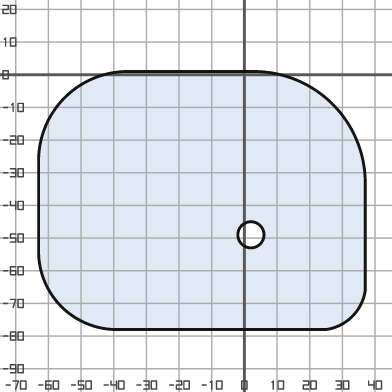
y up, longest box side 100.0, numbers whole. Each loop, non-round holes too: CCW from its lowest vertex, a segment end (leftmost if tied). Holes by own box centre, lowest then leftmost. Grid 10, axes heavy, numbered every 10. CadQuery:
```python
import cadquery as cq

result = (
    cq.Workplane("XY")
    .moveTo(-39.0, -78.0)
    .lineTo(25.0, -78.0)
    .threePointArc((33.0, -74.0), (37.0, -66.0))
    .lineTo(37.0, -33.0)
    .threePointArc((27.0, -9.0), (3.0, 1.0))
    .lineTo(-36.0, 1.0)
    .threePointArc((-55.0, -7.0), (-63.0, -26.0))
    .lineTo(-63.0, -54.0)
    .threePointArc((-56.0, -71.0), (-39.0, -78.0))
    .close()
    .moveTo(2.0, -49.0)
    .circle(4.0)
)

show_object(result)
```